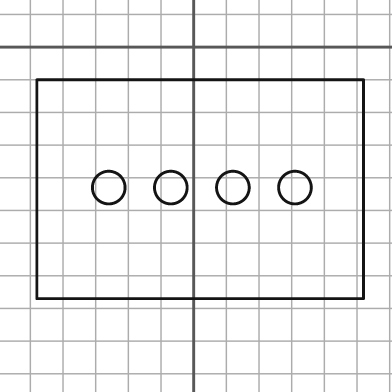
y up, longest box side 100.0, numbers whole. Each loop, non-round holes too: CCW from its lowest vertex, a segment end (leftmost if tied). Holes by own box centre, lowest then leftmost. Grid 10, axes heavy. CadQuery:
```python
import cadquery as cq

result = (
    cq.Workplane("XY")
    .moveTo(-48.0, -77.0)
    .lineTo(52.0, -77.0)
    .lineTo(52.0, -10.0)
    .lineTo(-48.0, -10.0)
    .close()
    .moveTo(-26.0, -43.0)
    .circle(5.0)
    .moveTo(-7.0, -43.0)
    .circle(5.0)
    .moveTo(12.0, -43.0)
    .circle(5.0)
    .moveTo(31.0, -43.0)
    .circle(5.0)
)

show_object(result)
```